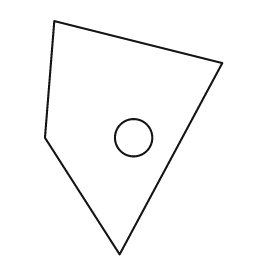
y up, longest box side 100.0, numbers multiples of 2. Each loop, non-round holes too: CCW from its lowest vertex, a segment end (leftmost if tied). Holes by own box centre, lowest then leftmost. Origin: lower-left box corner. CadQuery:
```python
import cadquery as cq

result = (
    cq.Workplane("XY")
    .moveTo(32.0, 0.0)
    .lineTo(76.0, 82.0)
    .lineTo(4.0, 100.0)
    .lineTo(0.0, 50.0)
    .close()
    .moveTo(38.0, 50.0)
    .circle(8.0)
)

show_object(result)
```